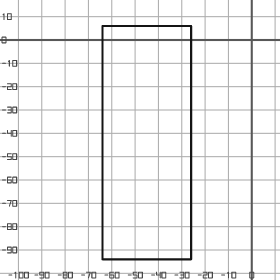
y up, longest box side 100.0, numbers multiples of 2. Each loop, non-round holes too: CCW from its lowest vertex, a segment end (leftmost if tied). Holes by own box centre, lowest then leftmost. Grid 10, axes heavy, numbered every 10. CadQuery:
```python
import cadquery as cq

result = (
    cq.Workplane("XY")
    .moveTo(-64.0, -94.0)
    .lineTo(-26.0, -94.0)
    .lineTo(-26.0, 6.0)
    .lineTo(-64.0, 6.0)
    .close()
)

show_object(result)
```